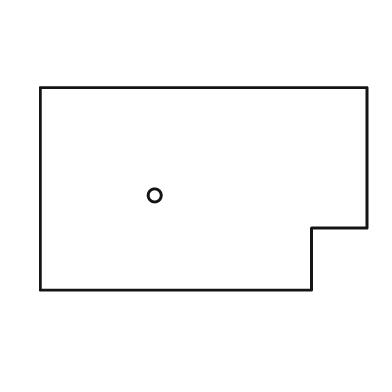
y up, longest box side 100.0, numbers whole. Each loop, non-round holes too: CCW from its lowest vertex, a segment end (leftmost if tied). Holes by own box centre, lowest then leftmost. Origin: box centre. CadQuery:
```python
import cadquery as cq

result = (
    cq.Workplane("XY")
    .moveTo(-50.0, -31.0)
    .lineTo(33.0, -31.0)
    .lineTo(33.0, -12.0)
    .lineTo(50.0, -12.0)
    .lineTo(50.0, 31.0)
    .lineTo(-50.0, 31.0)
    .close()
    .moveTo(-15.0, -2.0)
    .circle(2.0)
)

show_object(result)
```